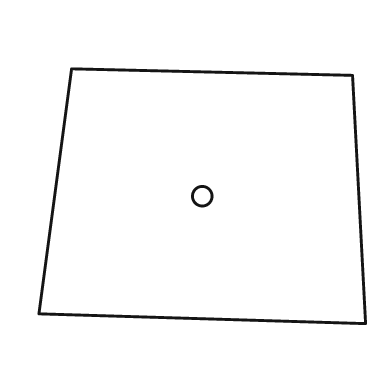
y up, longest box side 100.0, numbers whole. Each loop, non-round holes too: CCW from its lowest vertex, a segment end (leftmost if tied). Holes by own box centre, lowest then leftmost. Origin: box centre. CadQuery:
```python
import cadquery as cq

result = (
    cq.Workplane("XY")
    .moveTo(50.0, -39.0)
    .lineTo(46.0, 37.0)
    .lineTo(-40.0, 39.0)
    .lineTo(-50.0, -36.0)
    .close()
    .moveTo(0.0, 0.0)
    .circle(3.0)
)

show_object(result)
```